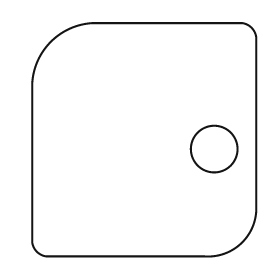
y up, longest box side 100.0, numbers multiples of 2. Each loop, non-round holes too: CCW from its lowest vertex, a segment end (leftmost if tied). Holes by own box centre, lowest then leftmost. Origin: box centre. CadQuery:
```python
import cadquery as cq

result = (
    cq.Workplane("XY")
    .moveTo(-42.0, -50.0)
    .lineTo(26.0, -50.0)
    .threePointArc((42.0, -44.0), (48.0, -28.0))
    .lineTo(48.0, 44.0)
    .threePointArc((46.0, 48.0), (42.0, 50.0))
    .lineTo(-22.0, 50.0)
    .threePointArc((-40.0, 42.0), (-48.0, 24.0))
    .lineTo(-48.0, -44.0)
    .threePointArc((-46.0, -48.0), (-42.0, -50.0))
    .close()
    .moveTo(30.0, -4.0)
    .circle(10.0)
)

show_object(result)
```